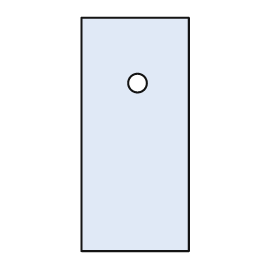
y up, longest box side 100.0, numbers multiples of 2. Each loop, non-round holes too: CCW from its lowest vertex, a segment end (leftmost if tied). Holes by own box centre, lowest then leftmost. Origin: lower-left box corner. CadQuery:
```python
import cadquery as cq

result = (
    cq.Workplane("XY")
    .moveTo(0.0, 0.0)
    .lineTo(46.0, 0.0)
    .lineTo(46.0, 100.0)
    .lineTo(0.0, 100.0)
    .close()
    .moveTo(24.0, 72.0)
    .circle(4.0)
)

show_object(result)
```